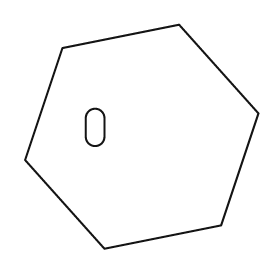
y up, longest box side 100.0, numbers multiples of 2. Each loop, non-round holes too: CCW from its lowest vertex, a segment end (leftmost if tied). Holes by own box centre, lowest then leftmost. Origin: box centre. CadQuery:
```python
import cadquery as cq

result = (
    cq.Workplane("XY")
    .moveTo(-16.0, -48.0)
    .lineTo(34.0, -38.0)
    .lineTo(50.0, 10.0)
    .lineTo(16.0, 48.0)
    .lineTo(-34.0, 38.0)
    .lineTo(-50.0, -10.0)
    .close()
    .moveTo(-24.0, 0.0)
    .threePointArc((-20.0, -4.0), (-16.0, 0.0))
    .lineTo(-16.0, 8.0)
    .threePointArc((-20.0, 12.0), (-24.0, 8.0))
    .close()
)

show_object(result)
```